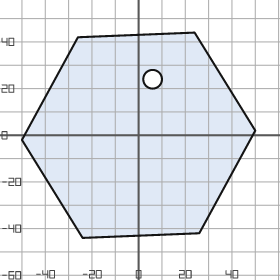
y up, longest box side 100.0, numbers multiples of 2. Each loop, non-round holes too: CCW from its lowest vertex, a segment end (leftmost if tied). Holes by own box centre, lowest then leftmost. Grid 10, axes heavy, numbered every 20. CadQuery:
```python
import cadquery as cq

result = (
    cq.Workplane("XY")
    .moveTo(-24.0, -44.0)
    .lineTo(26.0, -42.0)
    .lineTo(50.0, 2.0)
    .lineTo(24.0, 44.0)
    .lineTo(-26.0, 42.0)
    .lineTo(-50.0, -2.0)
    .close()
    .moveTo(6.0, 24.0)
    .circle(4.0)
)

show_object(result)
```